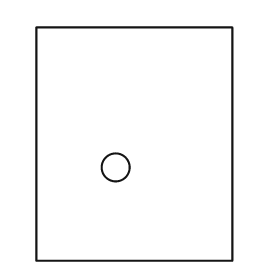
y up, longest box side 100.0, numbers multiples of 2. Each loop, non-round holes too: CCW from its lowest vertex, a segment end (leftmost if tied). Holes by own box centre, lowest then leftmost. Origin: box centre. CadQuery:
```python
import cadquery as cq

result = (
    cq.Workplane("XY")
    .moveTo(-42.0, -50.0)
    .lineTo(42.0, -50.0)
    .lineTo(42.0, 50.0)
    .lineTo(-42.0, 50.0)
    .close()
    .moveTo(-8.0, -10.0)
    .circle(6.0)
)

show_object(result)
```